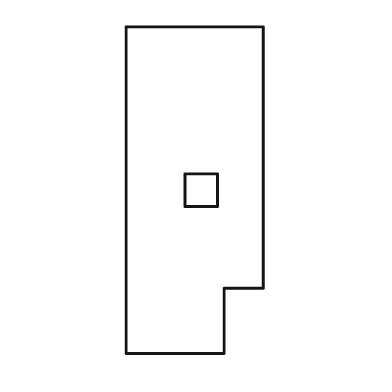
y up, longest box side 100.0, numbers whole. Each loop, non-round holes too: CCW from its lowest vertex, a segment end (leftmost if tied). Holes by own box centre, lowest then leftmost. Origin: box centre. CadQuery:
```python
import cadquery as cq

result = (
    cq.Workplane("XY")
    .moveTo(-21.0, -50.0)
    .lineTo(9.0, -50.0)
    .lineTo(9.0, -30.0)
    .lineTo(21.0, -30.0)
    .lineTo(21.0, 50.0)
    .lineTo(-21.0, 50.0)
    .close()
    .moveTo(-3.0, -5.0)
    .lineTo(7.0, -5.0)
    .lineTo(7.0, 5.0)
    .lineTo(-3.0, 5.0)
    .close()
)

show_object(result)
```